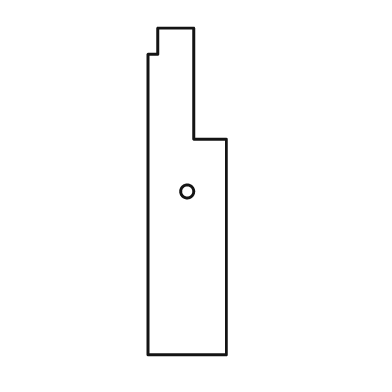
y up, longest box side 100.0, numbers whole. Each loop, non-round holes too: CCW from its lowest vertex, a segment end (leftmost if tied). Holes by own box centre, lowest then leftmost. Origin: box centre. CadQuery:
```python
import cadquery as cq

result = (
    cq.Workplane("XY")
    .moveTo(-12.0, -50.0)
    .lineTo(12.0, -50.0)
    .lineTo(12.0, 16.0)
    .lineTo(2.0, 16.0)
    .lineTo(2.0, 50.0)
    .lineTo(-9.0, 50.0)
    .lineTo(-9.0, 42.0)
    .lineTo(-12.0, 42.0)
    .close()
    .moveTo(0.0, 0.0)
    .circle(2.0)
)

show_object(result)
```